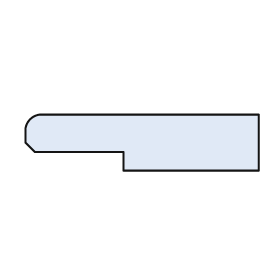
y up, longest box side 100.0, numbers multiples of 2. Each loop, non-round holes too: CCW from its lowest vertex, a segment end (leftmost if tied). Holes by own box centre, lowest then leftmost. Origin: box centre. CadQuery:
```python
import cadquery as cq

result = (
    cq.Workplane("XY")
    .moveTo(-8.0, -12.0)
    .lineTo(50.0, -12.0)
    .lineTo(50.0, 12.0)
    .lineTo(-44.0, 12.0)
    .threePointArc((-48.0, 10.0), (-50.0, 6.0))
    .lineTo(-50.0, 0.0)
    .lineTo(-46.0, -4.0)
    .lineTo(-8.0, -4.0)
    .close()
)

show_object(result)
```